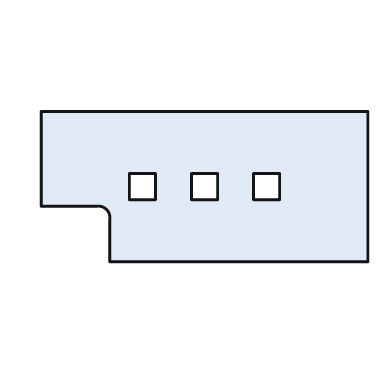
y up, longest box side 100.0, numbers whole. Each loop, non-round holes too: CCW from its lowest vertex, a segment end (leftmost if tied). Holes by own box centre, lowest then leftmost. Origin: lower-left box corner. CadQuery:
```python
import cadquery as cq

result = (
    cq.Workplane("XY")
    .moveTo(21.0, 0.0)
    .lineTo(100.0, 0.0)
    .lineTo(100.0, 46.0)
    .lineTo(0.0, 46.0)
    .lineTo(0.0, 17.0)
    .lineTo(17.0, 17.0)
    .threePointArc((20.0, 16.0), (21.0, 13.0))
    .close()
    .moveTo(27.0, 19.0)
    .lineTo(35.0, 19.0)
    .lineTo(35.0, 27.0)
    .lineTo(27.0, 27.0)
    .close()
    .moveTo(46.0, 19.0)
    .lineTo(54.0, 19.0)
    .lineTo(54.0, 27.0)
    .lineTo(46.0, 27.0)
    .close()
    .moveTo(65.0, 19.0)
    .lineTo(73.0, 19.0)
    .lineTo(73.0, 27.0)
    .lineTo(65.0, 27.0)
    .close()
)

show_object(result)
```